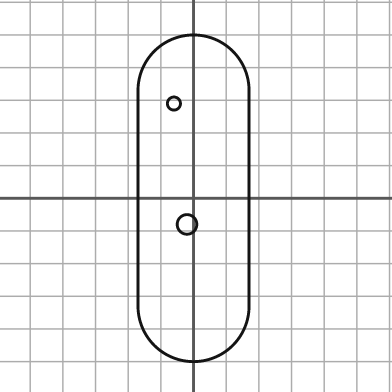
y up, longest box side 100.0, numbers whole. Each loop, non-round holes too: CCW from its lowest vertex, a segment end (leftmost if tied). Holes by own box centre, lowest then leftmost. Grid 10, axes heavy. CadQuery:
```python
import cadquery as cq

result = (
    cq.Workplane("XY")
    .moveTo(-17.0, -33.0)
    .threePointArc((0.0, -50.0), (17.0, -33.0))
    .lineTo(17.0, 33.0)
    .threePointArc((0.0, 50.0), (-17.0, 33.0))
    .close()
    .moveTo(-2.0, -8.0)
    .circle(3.0)
    .moveTo(-6.0, 29.0)
    .circle(2.0)
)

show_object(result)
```